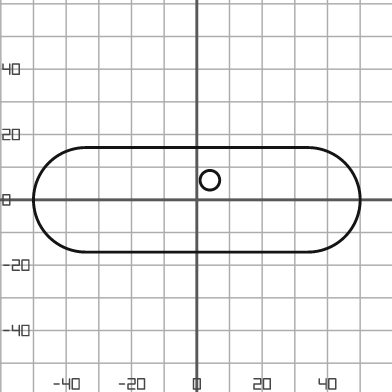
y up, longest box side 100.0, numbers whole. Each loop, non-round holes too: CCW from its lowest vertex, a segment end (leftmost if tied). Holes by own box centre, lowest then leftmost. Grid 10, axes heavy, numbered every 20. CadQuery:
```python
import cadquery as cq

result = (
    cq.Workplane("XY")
    .moveTo(-34.0, -16.0)
    .lineTo(34.0, -16.0)
    .threePointArc((50.0, 0.0), (34.0, 16.0))
    .lineTo(-34.0, 16.0)
    .threePointArc((-50.0, 0.0), (-34.0, -16.0))
    .close()
    .moveTo(4.0, 6.0)
    .circle(3.0)
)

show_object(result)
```